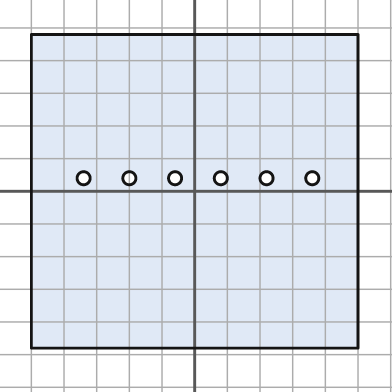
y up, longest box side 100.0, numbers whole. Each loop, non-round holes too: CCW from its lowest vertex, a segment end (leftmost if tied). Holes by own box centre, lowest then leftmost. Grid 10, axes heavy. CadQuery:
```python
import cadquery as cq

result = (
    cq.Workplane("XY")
    .moveTo(-50.0, -48.0)
    .lineTo(50.0, -48.0)
    .lineTo(50.0, 48.0)
    .lineTo(-50.0, 48.0)
    .close()
    .moveTo(-34.0, 4.0)
    .circle(2.0)
    .moveTo(-20.0, 4.0)
    .circle(2.0)
    .moveTo(-6.0, 4.0)
    .circle(2.0)
    .moveTo(8.0, 4.0)
    .circle(2.0)
    .moveTo(22.0, 4.0)
    .circle(2.0)
    .moveTo(36.0, 4.0)
    .circle(2.0)
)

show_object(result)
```